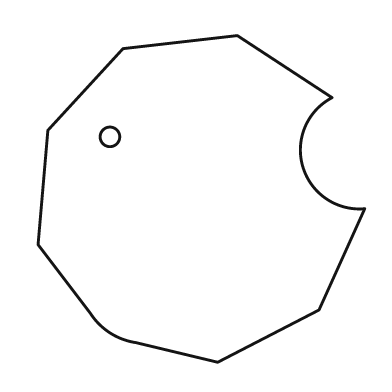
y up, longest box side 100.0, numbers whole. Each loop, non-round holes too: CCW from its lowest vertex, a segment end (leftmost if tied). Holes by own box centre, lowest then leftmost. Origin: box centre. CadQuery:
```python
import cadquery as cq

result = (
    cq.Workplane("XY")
    .moveTo(5.0, -50.0)
    .lineTo(36.0, -34.0)
    .lineTo(50.0, -3.0)
    .threePointArc((31.0, 10.0), (40.0, 31.0))
    .lineTo(11.0, 50.0)
    .lineTo(-24.0, 46.0)
    .lineTo(-47.0, 21.0)
    .lineTo(-50.0, -14.0)
    .lineTo(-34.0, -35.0)
    .threePointArc((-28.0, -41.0), (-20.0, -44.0))
    .close()
    .moveTo(-28.0, 19.0)
    .circle(3.0)
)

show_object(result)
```